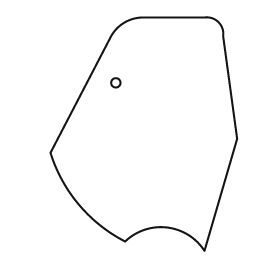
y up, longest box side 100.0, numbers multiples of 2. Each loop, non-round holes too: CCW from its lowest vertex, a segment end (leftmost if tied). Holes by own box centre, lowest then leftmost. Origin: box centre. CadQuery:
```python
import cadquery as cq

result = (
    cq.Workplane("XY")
    .moveTo(26.0, -50.0)
    .lineTo(40.0, -2.0)
    .lineTo(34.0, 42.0)
    .threePointArc((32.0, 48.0), (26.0, 50.0))
    .lineTo(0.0, 50.0)
    .threePointArc((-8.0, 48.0), (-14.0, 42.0))
    .lineTo(-40.0, -8.0)
    .threePointArc((-28.0, -30.0), (-8.0, -46.0))
    .threePointArc((10.0, -40.0), (26.0, -50.0))
    .close()
    .moveTo(-12.0, 22.0)
    .circle(2.0)
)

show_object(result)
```